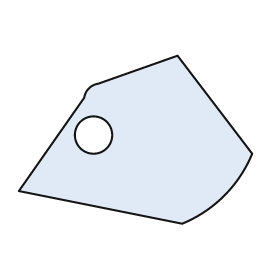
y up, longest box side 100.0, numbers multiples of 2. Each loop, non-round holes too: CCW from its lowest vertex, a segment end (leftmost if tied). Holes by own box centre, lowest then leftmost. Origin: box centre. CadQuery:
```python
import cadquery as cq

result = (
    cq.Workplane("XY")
    .moveTo(20.0, -36.0)
    .threePointArc((38.0, -24.0), (50.0, -6.0))
    .lineTo(18.0, 36.0)
    .lineTo(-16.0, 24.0)
    .threePointArc((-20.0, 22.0), (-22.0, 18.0))
    .lineTo(-50.0, -22.0)
    .close()
    .moveTo(-18.0, 2.0)
    .circle(8.0)
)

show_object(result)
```